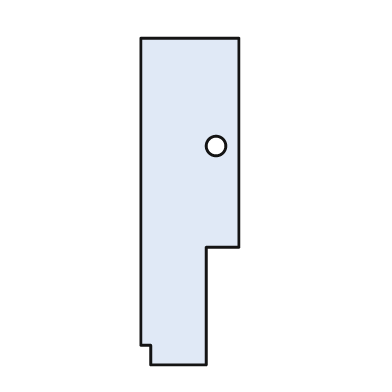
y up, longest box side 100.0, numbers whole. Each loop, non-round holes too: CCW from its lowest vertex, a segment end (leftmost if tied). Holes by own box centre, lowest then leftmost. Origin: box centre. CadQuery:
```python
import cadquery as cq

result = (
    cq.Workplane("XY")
    .moveTo(-12.0, -50.0)
    .lineTo(5.0, -50.0)
    .lineTo(5.0, -14.0)
    .lineTo(15.0, -14.0)
    .lineTo(15.0, 50.0)
    .lineTo(-15.0, 50.0)
    .lineTo(-15.0, -44.0)
    .lineTo(-12.0, -44.0)
    .close()
    .moveTo(8.0, 17.0)
    .circle(3.0)
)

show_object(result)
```